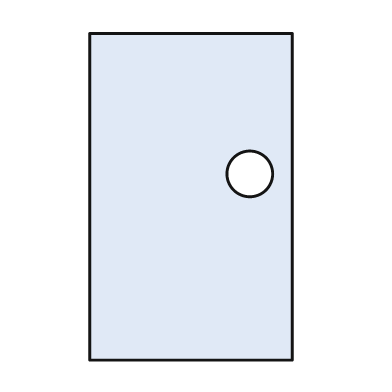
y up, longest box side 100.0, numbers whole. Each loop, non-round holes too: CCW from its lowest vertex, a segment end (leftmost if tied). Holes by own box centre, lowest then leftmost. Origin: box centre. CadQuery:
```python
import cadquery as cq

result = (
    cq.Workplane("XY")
    .moveTo(-31.0, -50.0)
    .lineTo(31.0, -50.0)
    .lineTo(31.0, 50.0)
    .lineTo(-31.0, 50.0)
    .close()
    .moveTo(18.0, 7.0)
    .circle(7.0)
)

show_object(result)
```